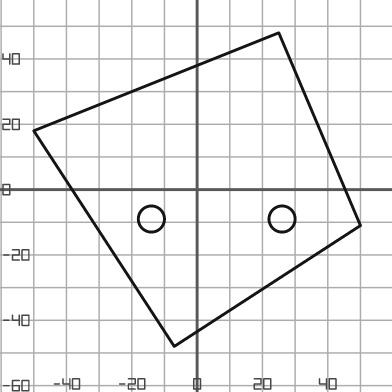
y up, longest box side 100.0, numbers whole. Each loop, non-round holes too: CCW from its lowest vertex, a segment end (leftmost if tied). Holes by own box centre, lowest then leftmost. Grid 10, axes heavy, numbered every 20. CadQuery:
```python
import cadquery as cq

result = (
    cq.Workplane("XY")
    .moveTo(-7.0, -48.0)
    .lineTo(50.0, -11.0)
    .lineTo(25.0, 48.0)
    .lineTo(-50.0, 18.0)
    .close()
    .moveTo(-14.0, -9.0)
    .circle(4.0)
    .moveTo(26.0, -9.0)
    .circle(4.0)
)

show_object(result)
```